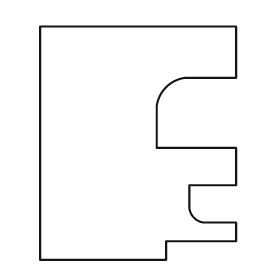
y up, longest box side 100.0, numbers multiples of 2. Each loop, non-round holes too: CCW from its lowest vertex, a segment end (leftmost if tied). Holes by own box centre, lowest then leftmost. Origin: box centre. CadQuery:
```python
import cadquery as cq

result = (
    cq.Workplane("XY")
    .moveTo(-42.0, -50.0)
    .lineTo(12.0, -50.0)
    .lineTo(12.0, -42.0)
    .lineTo(42.0, -42.0)
    .lineTo(42.0, -34.0)
    .lineTo(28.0, -34.0)
    .threePointArc((24.0, -32.0), (22.0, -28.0))
    .lineTo(22.0, -18.0)
    .lineTo(42.0, -18.0)
    .lineTo(42.0, -2.0)
    .lineTo(8.0, -2.0)
    .lineTo(8.0, 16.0)
    .threePointArc((12.0, 24.0), (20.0, 28.0))
    .lineTo(42.0, 28.0)
    .lineTo(42.0, 50.0)
    .lineTo(-42.0, 50.0)
    .close()
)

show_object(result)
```